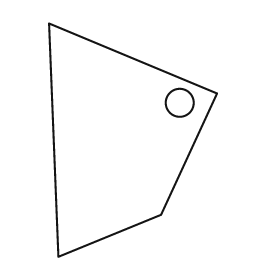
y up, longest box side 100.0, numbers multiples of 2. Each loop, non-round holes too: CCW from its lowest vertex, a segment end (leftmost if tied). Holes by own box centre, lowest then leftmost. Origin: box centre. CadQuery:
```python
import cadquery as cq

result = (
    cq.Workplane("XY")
    .moveTo(-32.0, -50.0)
    .lineTo(12.0, -32.0)
    .lineTo(36.0, 20.0)
    .lineTo(-36.0, 50.0)
    .close()
    .moveTo(20.0, 16.0)
    .circle(6.0)
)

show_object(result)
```